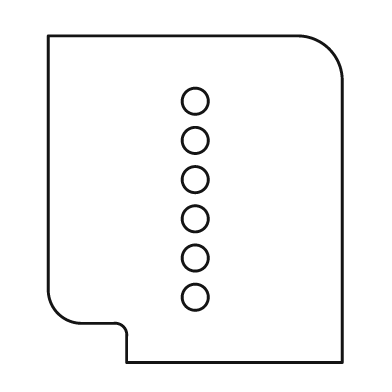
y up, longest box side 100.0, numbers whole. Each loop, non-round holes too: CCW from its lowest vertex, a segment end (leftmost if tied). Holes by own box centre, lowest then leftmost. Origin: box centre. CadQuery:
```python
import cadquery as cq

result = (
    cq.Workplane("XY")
    .moveTo(-21.0, -50.0)
    .lineTo(45.0, -50.0)
    .lineTo(45.0, 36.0)
    .threePointArc((41.0, 46.0), (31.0, 50.0))
    .lineTo(-45.0, 50.0)
    .lineTo(-45.0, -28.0)
    .threePointArc((-42.0, -35.0), (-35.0, -38.0))
    .lineTo(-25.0, -38.0)
    .threePointArc((-22.0, -39.0), (-21.0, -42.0))
    .close()
    .moveTo(0.0, -30.0)
    .circle(4.0)
    .moveTo(0.0, -18.0)
    .circle(4.0)
    .moveTo(0.0, -6.0)
    .circle(4.0)
    .moveTo(0.0, 6.0)
    .circle(4.0)
    .moveTo(0.0, 18.0)
    .circle(4.0)
    .moveTo(0.0, 30.0)
    .circle(4.0)
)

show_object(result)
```